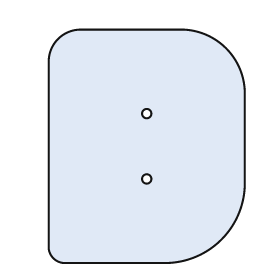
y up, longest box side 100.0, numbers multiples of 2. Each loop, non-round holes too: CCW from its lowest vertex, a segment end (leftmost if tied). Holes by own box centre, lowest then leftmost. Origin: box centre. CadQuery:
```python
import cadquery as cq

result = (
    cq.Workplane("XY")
    .moveTo(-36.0, -50.0)
    .lineTo(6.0, -50.0)
    .threePointArc((32.0, -40.0), (42.0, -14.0))
    .lineTo(42.0, 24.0)
    .threePointArc((34.0, 42.0), (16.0, 50.0))
    .lineTo(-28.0, 50.0)
    .threePointArc((-38.0, 46.0), (-42.0, 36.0))
    .lineTo(-42.0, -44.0)
    .threePointArc((-40.0, -48.0), (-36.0, -50.0))
    .close()
    .moveTo(0.0, -14.0)
    .circle(2.0)
    .moveTo(0.0, 14.0)
    .circle(2.0)
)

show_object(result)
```